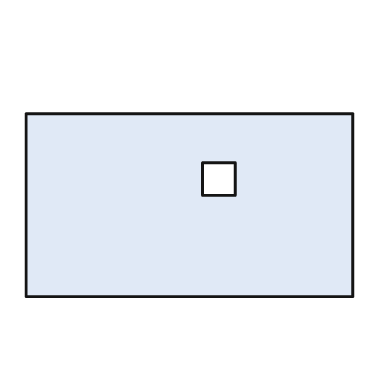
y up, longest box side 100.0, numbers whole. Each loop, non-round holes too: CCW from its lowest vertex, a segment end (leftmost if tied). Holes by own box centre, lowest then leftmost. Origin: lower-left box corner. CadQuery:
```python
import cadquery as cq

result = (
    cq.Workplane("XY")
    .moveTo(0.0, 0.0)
    .lineTo(100.0, 0.0)
    .lineTo(100.0, 56.0)
    .lineTo(0.0, 56.0)
    .close()
    .moveTo(54.0, 31.0)
    .lineTo(64.0, 31.0)
    .lineTo(64.0, 41.0)
    .lineTo(54.0, 41.0)
    .close()
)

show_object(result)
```